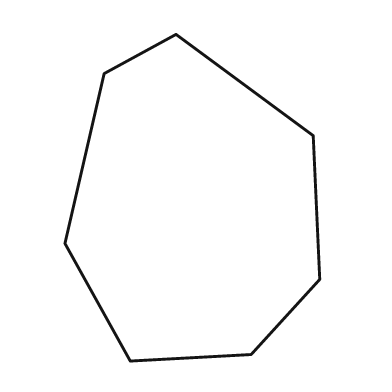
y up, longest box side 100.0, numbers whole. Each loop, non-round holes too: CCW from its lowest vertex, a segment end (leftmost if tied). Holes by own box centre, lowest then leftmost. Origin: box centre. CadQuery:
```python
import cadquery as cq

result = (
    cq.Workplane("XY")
    .moveTo(-19.0, -50.0)
    .lineTo(18.0, -48.0)
    .lineTo(39.0, -25.0)
    .lineTo(37.0, 19.0)
    .lineTo(-5.0, 50.0)
    .lineTo(-27.0, 38.0)
    .lineTo(-39.0, -14.0)
    .close()
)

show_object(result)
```